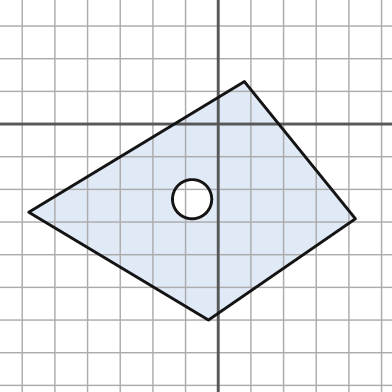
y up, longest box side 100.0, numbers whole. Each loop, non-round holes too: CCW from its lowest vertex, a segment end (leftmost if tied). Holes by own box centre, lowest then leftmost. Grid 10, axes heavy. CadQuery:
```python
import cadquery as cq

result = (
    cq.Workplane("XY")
    .moveTo(-3.0, -60.0)
    .lineTo(42.0, -29.0)
    .lineTo(8.0, 13.0)
    .lineTo(-58.0, -27.0)
    .close()
    .moveTo(-8.0, -23.0)
    .circle(6.0)
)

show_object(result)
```